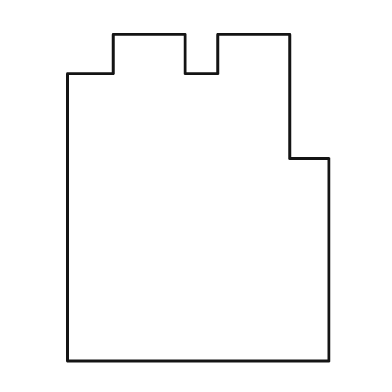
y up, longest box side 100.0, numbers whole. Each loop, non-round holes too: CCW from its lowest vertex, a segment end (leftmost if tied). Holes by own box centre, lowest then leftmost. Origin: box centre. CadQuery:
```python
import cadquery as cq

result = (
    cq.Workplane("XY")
    .moveTo(-40.0, -50.0)
    .lineTo(40.0, -50.0)
    .lineTo(40.0, 12.0)
    .lineTo(28.0, 12.0)
    .lineTo(28.0, 50.0)
    .lineTo(6.0, 50.0)
    .lineTo(6.0, 38.0)
    .lineTo(-4.0, 38.0)
    .lineTo(-4.0, 50.0)
    .lineTo(-26.0, 50.0)
    .lineTo(-26.0, 38.0)
    .lineTo(-40.0, 38.0)
    .close()
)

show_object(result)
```